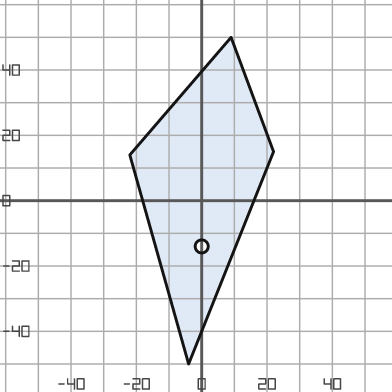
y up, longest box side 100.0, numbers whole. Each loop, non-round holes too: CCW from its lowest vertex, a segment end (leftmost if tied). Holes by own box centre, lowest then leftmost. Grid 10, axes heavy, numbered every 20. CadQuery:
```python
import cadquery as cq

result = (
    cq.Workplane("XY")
    .moveTo(-4.0, -50.0)
    .lineTo(22.0, 15.0)
    .lineTo(9.0, 50.0)
    .lineTo(-22.0, 14.0)
    .close()
    .moveTo(0.0, -14.0)
    .circle(2.0)
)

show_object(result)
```